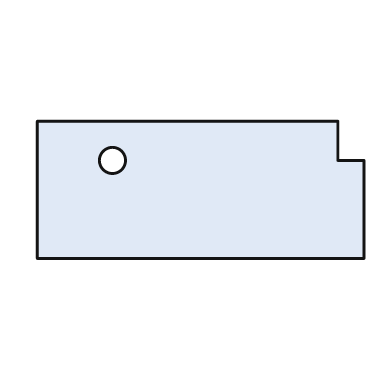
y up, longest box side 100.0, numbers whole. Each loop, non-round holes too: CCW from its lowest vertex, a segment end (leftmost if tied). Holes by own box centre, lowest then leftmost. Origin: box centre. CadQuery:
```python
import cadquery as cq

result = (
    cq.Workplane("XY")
    .moveTo(-50.0, -21.0)
    .lineTo(50.0, -21.0)
    .lineTo(50.0, 9.0)
    .lineTo(42.0, 9.0)
    .lineTo(42.0, 21.0)
    .lineTo(-50.0, 21.0)
    .close()
    .moveTo(-27.0, 9.0)
    .circle(4.0)
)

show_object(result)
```